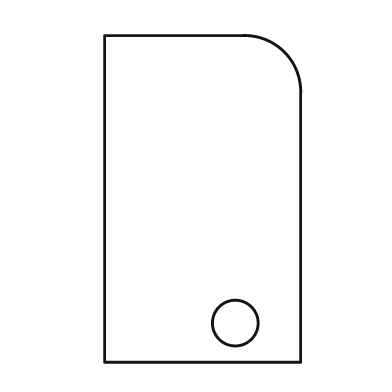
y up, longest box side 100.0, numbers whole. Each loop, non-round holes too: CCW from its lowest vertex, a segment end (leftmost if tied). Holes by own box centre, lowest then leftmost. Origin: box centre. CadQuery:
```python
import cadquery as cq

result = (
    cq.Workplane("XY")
    .moveTo(-30.0, -50.0)
    .lineTo(30.0, -50.0)
    .lineTo(30.0, 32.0)
    .threePointArc((25.0, 45.0), (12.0, 50.0))
    .lineTo(-30.0, 50.0)
    .close()
    .moveTo(10.0, -38.0)
    .circle(7.0)
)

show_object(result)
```